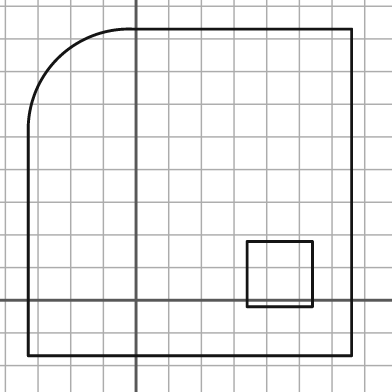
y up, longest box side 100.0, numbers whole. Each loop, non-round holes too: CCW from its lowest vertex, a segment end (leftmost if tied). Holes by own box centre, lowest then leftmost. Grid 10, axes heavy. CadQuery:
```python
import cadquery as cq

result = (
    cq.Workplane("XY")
    .moveTo(-33.0, -17.0)
    .lineTo(66.0, -17.0)
    .lineTo(66.0, 83.0)
    .lineTo(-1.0, 83.0)
    .threePointArc((-24.0, 74.0), (-33.0, 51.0))
    .close()
    .moveTo(34.0, -2.0)
    .lineTo(54.0, -2.0)
    .lineTo(54.0, 18.0)
    .lineTo(34.0, 18.0)
    .close()
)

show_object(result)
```